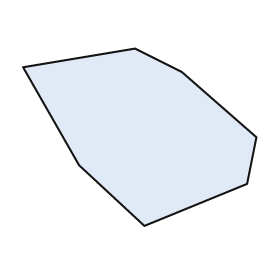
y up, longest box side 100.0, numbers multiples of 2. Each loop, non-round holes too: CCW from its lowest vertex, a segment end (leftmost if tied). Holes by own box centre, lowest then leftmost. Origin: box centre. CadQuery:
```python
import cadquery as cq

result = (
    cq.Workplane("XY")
    .moveTo(2.0, -38.0)
    .lineTo(46.0, -20.0)
    .lineTo(50.0, 0.0)
    .lineTo(18.0, 28.0)
    .lineTo(-2.0, 38.0)
    .lineTo(-50.0, 30.0)
    .lineTo(-26.0, -12.0)
    .close()
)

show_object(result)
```